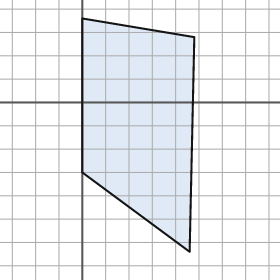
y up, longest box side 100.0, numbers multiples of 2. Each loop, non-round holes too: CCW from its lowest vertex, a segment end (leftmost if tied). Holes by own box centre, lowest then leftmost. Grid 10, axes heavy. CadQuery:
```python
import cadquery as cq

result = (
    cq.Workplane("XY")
    .moveTo(46.0, -64.0)
    .lineTo(48.0, 28.0)
    .lineTo(0.0, 36.0)
    .lineTo(0.0, -30.0)
    .close()
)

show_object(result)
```